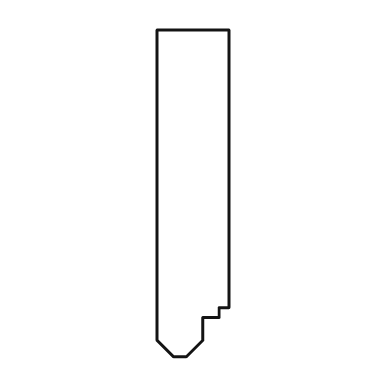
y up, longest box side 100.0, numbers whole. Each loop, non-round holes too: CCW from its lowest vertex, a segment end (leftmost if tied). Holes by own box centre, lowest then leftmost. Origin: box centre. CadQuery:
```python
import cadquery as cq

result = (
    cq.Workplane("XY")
    .moveTo(-6.0, -50.0)
    .lineTo(-2.0, -50.0)
    .lineTo(3.0, -45.0)
    .lineTo(3.0, -38.0)
    .lineTo(8.0, -38.0)
    .lineTo(8.0, -35.0)
    .lineTo(11.0, -35.0)
    .lineTo(11.0, 50.0)
    .lineTo(-11.0, 50.0)
    .lineTo(-11.0, -45.0)
    .close()
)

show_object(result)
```